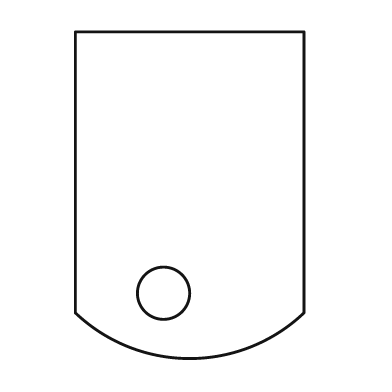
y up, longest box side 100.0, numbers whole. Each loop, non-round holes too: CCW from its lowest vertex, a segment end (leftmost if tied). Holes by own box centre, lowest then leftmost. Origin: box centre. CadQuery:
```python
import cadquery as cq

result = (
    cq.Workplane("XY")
    .moveTo(-35.0, -36.0)
    .threePointArc((0.0, -50.0), (35.0, -36.0))
    .lineTo(35.0, 50.0)
    .lineTo(-35.0, 50.0)
    .close()
    .moveTo(-8.0, -30.0)
    .circle(8.0)
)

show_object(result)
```